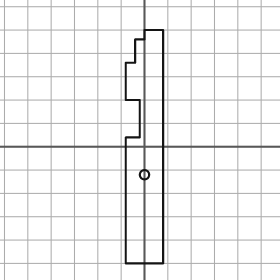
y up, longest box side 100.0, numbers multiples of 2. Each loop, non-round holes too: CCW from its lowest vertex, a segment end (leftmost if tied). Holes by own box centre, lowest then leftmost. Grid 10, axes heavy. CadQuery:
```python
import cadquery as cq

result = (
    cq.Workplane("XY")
    .moveTo(-8.0, -50.0)
    .lineTo(8.0, -50.0)
    .lineTo(8.0, 50.0)
    .lineTo(0.0, 50.0)
    .lineTo(0.0, 46.0)
    .lineTo(-4.0, 46.0)
    .lineTo(-4.0, 36.0)
    .lineTo(-8.0, 36.0)
    .lineTo(-8.0, 20.0)
    .lineTo(-2.0, 20.0)
    .lineTo(-2.0, 4.0)
    .lineTo(-8.0, 4.0)
    .close()
    .moveTo(0.0, -12.0)
    .circle(2.0)
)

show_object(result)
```